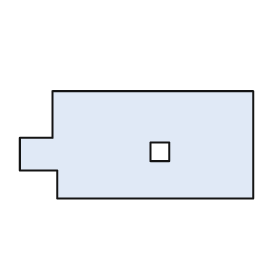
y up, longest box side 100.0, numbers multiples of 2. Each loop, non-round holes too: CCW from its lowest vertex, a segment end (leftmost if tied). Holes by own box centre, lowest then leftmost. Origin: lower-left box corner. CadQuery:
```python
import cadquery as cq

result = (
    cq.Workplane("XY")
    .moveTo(16.0, 0.0)
    .lineTo(100.0, 0.0)
    .lineTo(100.0, 46.0)
    .lineTo(14.0, 46.0)
    .lineTo(14.0, 26.0)
    .lineTo(0.0, 26.0)
    .lineTo(0.0, 12.0)
    .lineTo(16.0, 12.0)
    .close()
    .moveTo(56.0, 16.0)
    .lineTo(64.0, 16.0)
    .lineTo(64.0, 24.0)
    .lineTo(56.0, 24.0)
    .close()
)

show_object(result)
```